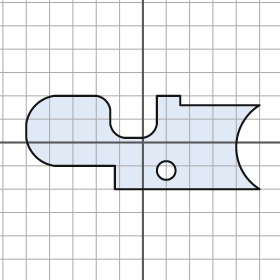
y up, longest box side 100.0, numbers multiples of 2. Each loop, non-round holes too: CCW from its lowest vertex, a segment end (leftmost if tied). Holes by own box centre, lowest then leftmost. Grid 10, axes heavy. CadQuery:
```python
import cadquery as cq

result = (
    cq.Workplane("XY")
    .moveTo(-12.0, -20.0)
    .lineTo(50.0, -20.0)
    .threePointArc((40.0, -2.0), (50.0, 16.0))
    .lineTo(16.0, 16.0)
    .lineTo(16.0, 20.0)
    .lineTo(6.0, 20.0)
    .lineTo(6.0, 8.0)
    .threePointArc((4.0, 4.0), (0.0, 2.0))
    .lineTo(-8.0, 2.0)
    .threePointArc((-12.0, 4.0), (-14.0, 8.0))
    .lineTo(-14.0, 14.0)
    .threePointArc((-16.0, 18.0), (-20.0, 20.0))
    .lineTo(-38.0, 20.0)
    .threePointArc((-46.0, 16.0), (-50.0, 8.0))
    .lineTo(-50.0, 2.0)
    .threePointArc((-46.0, -6.0), (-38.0, -10.0))
    .lineTo(-12.0, -10.0)
    .close()
    .moveTo(10.0, -12.0)
    .circle(4.0)
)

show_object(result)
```